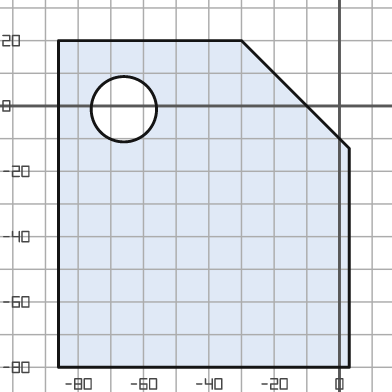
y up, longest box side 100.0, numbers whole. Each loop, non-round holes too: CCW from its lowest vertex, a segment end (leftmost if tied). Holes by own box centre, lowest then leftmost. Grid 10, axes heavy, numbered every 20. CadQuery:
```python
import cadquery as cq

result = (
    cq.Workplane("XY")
    .moveTo(-86.0, -80.0)
    .lineTo(3.0, -80.0)
    .lineTo(3.0, -13.0)
    .lineTo(-30.0, 20.0)
    .lineTo(-86.0, 20.0)
    .close()
    .moveTo(-66.0, -1.0)
    .circle(10.0)
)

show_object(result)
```